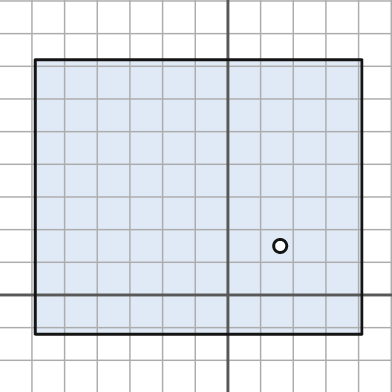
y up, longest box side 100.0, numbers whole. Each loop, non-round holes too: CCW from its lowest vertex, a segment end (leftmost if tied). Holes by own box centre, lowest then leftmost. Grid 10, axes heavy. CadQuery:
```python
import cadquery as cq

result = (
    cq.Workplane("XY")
    .moveTo(-59.0, -12.0)
    .lineTo(41.0, -12.0)
    .lineTo(41.0, 72.0)
    .lineTo(-59.0, 72.0)
    .close()
    .moveTo(16.0, 15.0)
    .circle(2.0)
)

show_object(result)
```